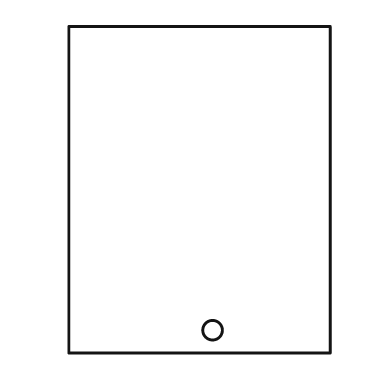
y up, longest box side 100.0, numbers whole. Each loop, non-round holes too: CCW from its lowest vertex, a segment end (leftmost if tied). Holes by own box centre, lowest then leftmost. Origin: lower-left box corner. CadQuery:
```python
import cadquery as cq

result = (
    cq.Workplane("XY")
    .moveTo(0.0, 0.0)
    .lineTo(80.0, 0.0)
    .lineTo(80.0, 100.0)
    .lineTo(0.0, 100.0)
    .close()
    .moveTo(44.0, 7.0)
    .circle(3.0)
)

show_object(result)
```